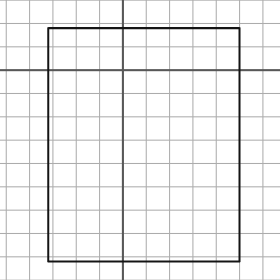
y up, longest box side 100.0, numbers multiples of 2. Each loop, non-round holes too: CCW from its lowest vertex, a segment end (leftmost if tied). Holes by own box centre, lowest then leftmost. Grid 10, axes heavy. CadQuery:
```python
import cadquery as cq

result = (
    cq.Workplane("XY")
    .moveTo(-32.0, -82.0)
    .lineTo(50.0, -82.0)
    .lineTo(50.0, 18.0)
    .lineTo(-32.0, 18.0)
    .close()
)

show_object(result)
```